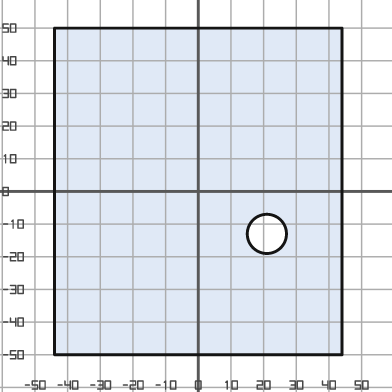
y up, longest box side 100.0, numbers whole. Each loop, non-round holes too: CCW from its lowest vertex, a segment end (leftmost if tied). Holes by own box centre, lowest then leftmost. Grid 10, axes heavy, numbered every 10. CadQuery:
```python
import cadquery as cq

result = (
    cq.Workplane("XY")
    .moveTo(-44.0, -50.0)
    .lineTo(44.0, -50.0)
    .lineTo(44.0, 50.0)
    .lineTo(-44.0, 50.0)
    .close()
    .moveTo(21.0, -13.0)
    .circle(6.0)
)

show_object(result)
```